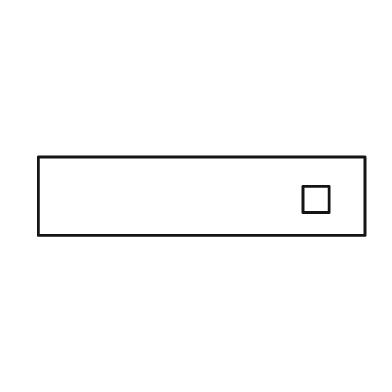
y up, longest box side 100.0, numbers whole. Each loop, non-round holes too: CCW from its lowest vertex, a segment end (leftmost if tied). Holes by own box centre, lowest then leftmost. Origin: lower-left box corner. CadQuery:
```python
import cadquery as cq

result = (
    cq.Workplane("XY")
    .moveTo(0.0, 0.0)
    .lineTo(100.0, 0.0)
    .lineTo(100.0, 24.0)
    .lineTo(0.0, 24.0)
    .close()
    .moveTo(81.0, 7.0)
    .lineTo(89.0, 7.0)
    .lineTo(89.0, 15.0)
    .lineTo(81.0, 15.0)
    .close()
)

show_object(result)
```